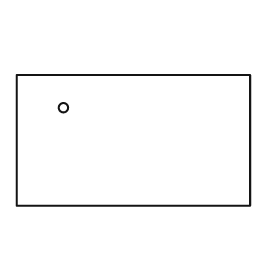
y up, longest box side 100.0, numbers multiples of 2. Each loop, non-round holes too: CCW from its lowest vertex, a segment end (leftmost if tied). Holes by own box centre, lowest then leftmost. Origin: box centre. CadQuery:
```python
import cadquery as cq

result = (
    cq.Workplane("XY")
    .moveTo(-50.0, -28.0)
    .lineTo(50.0, -28.0)
    .lineTo(50.0, 28.0)
    .lineTo(-50.0, 28.0)
    .close()
    .moveTo(-30.0, 14.0)
    .circle(2.0)
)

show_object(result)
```